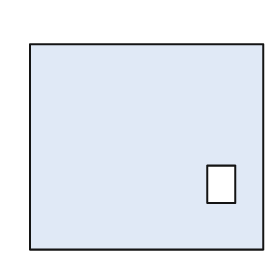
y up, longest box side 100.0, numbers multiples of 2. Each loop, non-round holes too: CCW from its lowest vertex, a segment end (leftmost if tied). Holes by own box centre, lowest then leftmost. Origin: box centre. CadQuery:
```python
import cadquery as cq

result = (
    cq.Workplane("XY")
    .moveTo(-50.0, -44.0)
    .lineTo(50.0, -44.0)
    .lineTo(50.0, 44.0)
    .lineTo(-50.0, 44.0)
    .close()
    .moveTo(26.0, -24.0)
    .lineTo(38.0, -24.0)
    .lineTo(38.0, -8.0)
    .lineTo(26.0, -8.0)
    .close()
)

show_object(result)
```